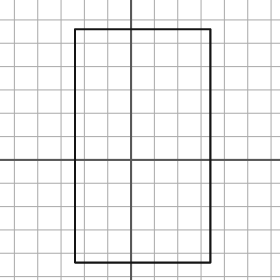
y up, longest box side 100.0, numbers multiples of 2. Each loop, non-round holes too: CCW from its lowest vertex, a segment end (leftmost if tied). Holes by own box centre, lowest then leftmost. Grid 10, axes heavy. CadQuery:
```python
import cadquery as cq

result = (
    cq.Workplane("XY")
    .moveTo(-24.0, -44.0)
    .lineTo(34.0, -44.0)
    .lineTo(34.0, 56.0)
    .lineTo(-24.0, 56.0)
    .close()
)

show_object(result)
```